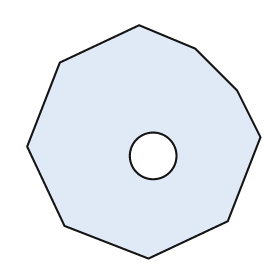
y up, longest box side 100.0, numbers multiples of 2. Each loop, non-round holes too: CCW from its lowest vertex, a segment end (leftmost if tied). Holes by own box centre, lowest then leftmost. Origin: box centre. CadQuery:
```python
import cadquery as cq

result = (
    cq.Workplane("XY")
    .moveTo(2.0, -50.0)
    .lineTo(36.0, -34.0)
    .lineTo(50.0, 2.0)
    .lineTo(40.0, 22.0)
    .lineTo(22.0, 40.0)
    .lineTo(-2.0, 50.0)
    .lineTo(-36.0, 34.0)
    .lineTo(-50.0, -2.0)
    .lineTo(-34.0, -36.0)
    .close()
    .moveTo(4.0, -6.0)
    .circle(10.0)
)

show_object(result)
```